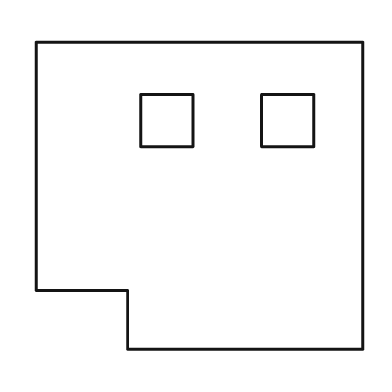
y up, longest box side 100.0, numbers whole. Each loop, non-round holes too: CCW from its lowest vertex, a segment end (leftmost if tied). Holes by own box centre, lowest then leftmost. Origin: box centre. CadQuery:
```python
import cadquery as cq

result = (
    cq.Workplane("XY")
    .moveTo(-22.0, -47.0)
    .lineTo(50.0, -47.0)
    .lineTo(50.0, 47.0)
    .lineTo(-50.0, 47.0)
    .lineTo(-50.0, -29.0)
    .lineTo(-22.0, -29.0)
    .close()
    .moveTo(-18.0, 15.0)
    .lineTo(-2.0, 15.0)
    .lineTo(-2.0, 31.0)
    .lineTo(-18.0, 31.0)
    .close()
    .moveTo(19.0, 15.0)
    .lineTo(35.0, 15.0)
    .lineTo(35.0, 31.0)
    .lineTo(19.0, 31.0)
    .close()
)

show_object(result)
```